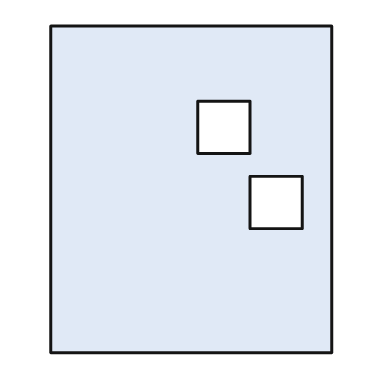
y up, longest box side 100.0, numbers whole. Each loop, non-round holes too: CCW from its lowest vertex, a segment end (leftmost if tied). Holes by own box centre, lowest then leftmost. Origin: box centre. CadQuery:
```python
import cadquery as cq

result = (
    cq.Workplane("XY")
    .moveTo(-43.0, -50.0)
    .lineTo(43.0, -50.0)
    .lineTo(43.0, 50.0)
    .lineTo(-43.0, 50.0)
    .close()
    .moveTo(18.0, -12.0)
    .lineTo(34.0, -12.0)
    .lineTo(34.0, 4.0)
    .lineTo(18.0, 4.0)
    .close()
    .moveTo(2.0, 11.0)
    .lineTo(18.0, 11.0)
    .lineTo(18.0, 27.0)
    .lineTo(2.0, 27.0)
    .close()
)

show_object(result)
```